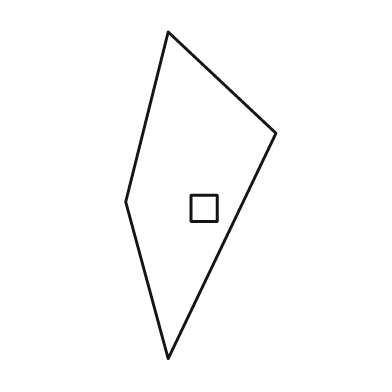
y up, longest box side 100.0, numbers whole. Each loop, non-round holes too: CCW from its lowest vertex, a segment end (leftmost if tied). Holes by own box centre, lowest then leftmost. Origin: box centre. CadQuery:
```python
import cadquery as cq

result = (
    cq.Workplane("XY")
    .moveTo(-10.0, -50.0)
    .lineTo(23.0, 19.0)
    .lineTo(-10.0, 50.0)
    .lineTo(-23.0, -2.0)
    .close()
    .moveTo(-3.0, -8.0)
    .lineTo(5.0, -8.0)
    .lineTo(5.0, 0.0)
    .lineTo(-3.0, 0.0)
    .close()
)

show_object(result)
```